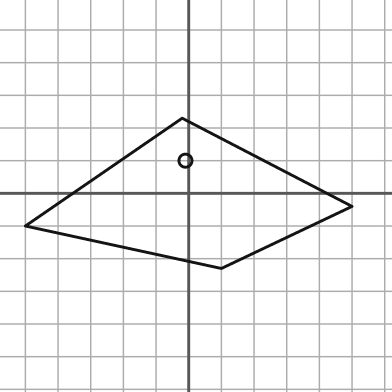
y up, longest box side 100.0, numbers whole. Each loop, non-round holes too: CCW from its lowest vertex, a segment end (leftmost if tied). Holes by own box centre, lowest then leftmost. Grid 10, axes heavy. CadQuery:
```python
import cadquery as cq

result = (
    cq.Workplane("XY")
    .moveTo(10.0, -23.0)
    .lineTo(50.0, -4.0)
    .lineTo(-2.0, 23.0)
    .lineTo(-50.0, -10.0)
    .close()
    .moveTo(-1.0, 10.0)
    .circle(2.0)
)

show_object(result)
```